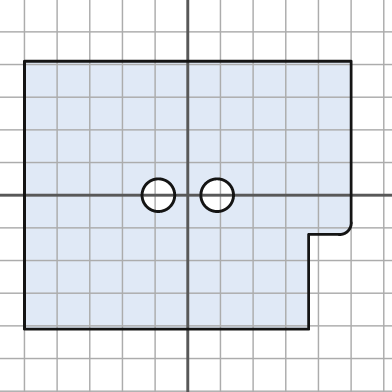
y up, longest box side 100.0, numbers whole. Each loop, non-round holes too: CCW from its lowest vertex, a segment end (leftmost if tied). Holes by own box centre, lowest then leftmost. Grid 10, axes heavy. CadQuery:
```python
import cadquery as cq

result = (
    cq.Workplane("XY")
    .moveTo(-50.0, -41.0)
    .lineTo(37.0, -41.0)
    .lineTo(37.0, -12.0)
    .lineTo(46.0, -12.0)
    .threePointArc((49.0, -11.0), (50.0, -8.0))
    .lineTo(50.0, 41.0)
    .lineTo(-50.0, 41.0)
    .close()
    .moveTo(-9.0, 0.0)
    .circle(5.0)
    .moveTo(9.0, 0.0)
    .circle(5.0)
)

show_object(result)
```